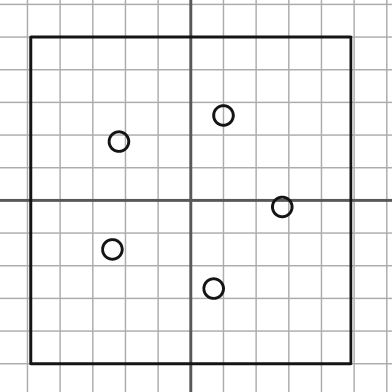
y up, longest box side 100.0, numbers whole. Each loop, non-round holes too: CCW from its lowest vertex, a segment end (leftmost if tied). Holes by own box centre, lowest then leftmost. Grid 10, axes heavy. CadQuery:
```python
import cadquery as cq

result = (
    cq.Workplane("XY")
    .moveTo(-49.0, -50.0)
    .lineTo(49.0, -50.0)
    .lineTo(49.0, 50.0)
    .lineTo(-49.0, 50.0)
    .close()
    .moveTo(7.0, -27.0)
    .circle(3.0)
    .moveTo(-24.0, -15.0)
    .circle(3.0)
    .moveTo(28.0, -2.0)
    .circle(3.0)
    .moveTo(-22.0, 18.0)
    .circle(3.0)
    .moveTo(10.0, 26.0)
    .circle(3.0)
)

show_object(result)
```